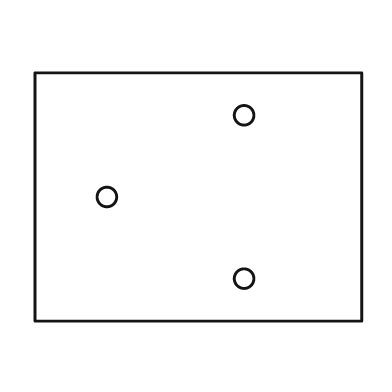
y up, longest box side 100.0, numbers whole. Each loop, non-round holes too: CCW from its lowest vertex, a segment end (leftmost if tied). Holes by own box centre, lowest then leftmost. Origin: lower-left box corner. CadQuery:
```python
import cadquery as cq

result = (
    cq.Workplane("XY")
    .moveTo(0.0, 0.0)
    .lineTo(100.0, 0.0)
    .lineTo(100.0, 76.0)
    .lineTo(0.0, 76.0)
    .close()
    .moveTo(64.0, 13.0)
    .circle(3.0)
    .moveTo(22.0, 38.0)
    .circle(3.0)
    .moveTo(64.0, 63.0)
    .circle(3.0)
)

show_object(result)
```